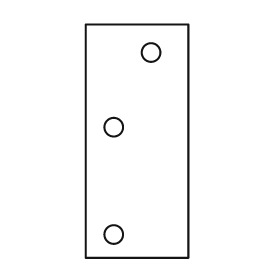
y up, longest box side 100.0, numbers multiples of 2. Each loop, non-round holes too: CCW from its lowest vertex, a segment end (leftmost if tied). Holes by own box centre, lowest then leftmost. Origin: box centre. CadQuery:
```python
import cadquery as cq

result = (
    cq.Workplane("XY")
    .moveTo(-22.0, -50.0)
    .lineTo(22.0, -50.0)
    .lineTo(22.0, 50.0)
    .lineTo(-22.0, 50.0)
    .close()
    .moveTo(-10.0, -40.0)
    .circle(4.0)
    .moveTo(-10.0, 6.0)
    .circle(4.0)
    .moveTo(6.0, 38.0)
    .circle(4.0)
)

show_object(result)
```